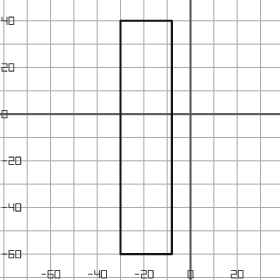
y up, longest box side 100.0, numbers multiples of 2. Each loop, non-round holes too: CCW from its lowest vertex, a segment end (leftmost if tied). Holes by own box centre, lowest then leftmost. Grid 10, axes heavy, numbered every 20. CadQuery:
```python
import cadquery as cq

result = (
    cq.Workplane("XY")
    .moveTo(-30.0, -60.0)
    .lineTo(-8.0, -60.0)
    .lineTo(-8.0, 40.0)
    .lineTo(-30.0, 40.0)
    .close()
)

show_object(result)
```